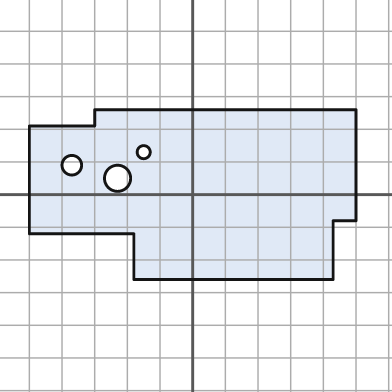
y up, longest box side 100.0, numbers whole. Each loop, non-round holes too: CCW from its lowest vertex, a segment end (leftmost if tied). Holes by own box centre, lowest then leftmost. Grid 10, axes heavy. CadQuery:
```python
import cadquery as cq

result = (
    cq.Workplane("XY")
    .moveTo(-18.0, -26.0)
    .lineTo(43.0, -26.0)
    .lineTo(43.0, -8.0)
    .lineTo(50.0, -8.0)
    .lineTo(50.0, 26.0)
    .lineTo(-30.0, 26.0)
    .lineTo(-30.0, 21.0)
    .lineTo(-50.0, 21.0)
    .lineTo(-50.0, -12.0)
    .lineTo(-18.0, -12.0)
    .close()
    .moveTo(-23.0, 5.0)
    .circle(4.0)
    .moveTo(-37.0, 9.0)
    .circle(3.0)
    .moveTo(-15.0, 13.0)
    .circle(2.0)
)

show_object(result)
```